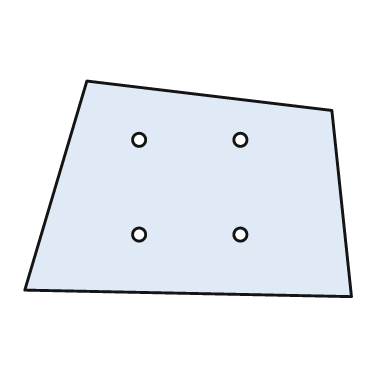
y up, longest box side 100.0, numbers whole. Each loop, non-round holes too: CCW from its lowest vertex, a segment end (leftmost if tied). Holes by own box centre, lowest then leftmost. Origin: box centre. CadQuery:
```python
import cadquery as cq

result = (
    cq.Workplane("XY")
    .moveTo(50.0, -33.0)
    .lineTo(44.0, 24.0)
    .lineTo(-31.0, 33.0)
    .lineTo(-50.0, -31.0)
    .close()
    .moveTo(-15.0, -14.0)
    .circle(2.0)
    .moveTo(16.0, -14.0)
    .circle(2.0)
    .moveTo(-15.0, 15.0)
    .circle(2.0)
    .moveTo(16.0, 15.0)
    .circle(2.0)
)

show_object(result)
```